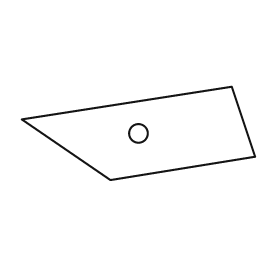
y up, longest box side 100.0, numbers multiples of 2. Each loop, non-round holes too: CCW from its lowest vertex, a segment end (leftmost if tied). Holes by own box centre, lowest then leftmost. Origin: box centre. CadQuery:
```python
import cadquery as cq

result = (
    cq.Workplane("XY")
    .moveTo(-12.0, -20.0)
    .lineTo(50.0, -10.0)
    .lineTo(40.0, 20.0)
    .lineTo(-50.0, 6.0)
    .close()
    .moveTo(0.0, 0.0)
    .circle(4.0)
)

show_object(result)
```